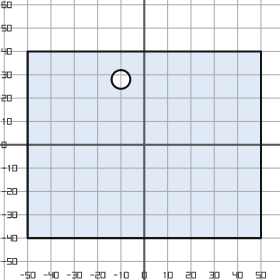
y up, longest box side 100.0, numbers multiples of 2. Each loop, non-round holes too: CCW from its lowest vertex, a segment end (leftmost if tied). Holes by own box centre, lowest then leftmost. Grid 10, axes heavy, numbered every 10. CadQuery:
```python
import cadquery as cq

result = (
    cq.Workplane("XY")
    .moveTo(-50.0, -40.0)
    .lineTo(50.0, -40.0)
    .lineTo(50.0, 40.0)
    .lineTo(-50.0, 40.0)
    .close()
    .moveTo(-10.0, 28.0)
    .circle(4.0)
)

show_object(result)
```